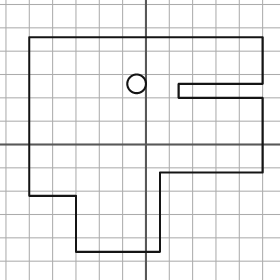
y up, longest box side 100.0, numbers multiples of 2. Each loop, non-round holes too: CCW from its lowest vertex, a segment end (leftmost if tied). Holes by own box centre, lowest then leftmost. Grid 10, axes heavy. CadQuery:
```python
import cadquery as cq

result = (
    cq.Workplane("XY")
    .moveTo(-30.0, -46.0)
    .lineTo(6.0, -46.0)
    .lineTo(6.0, -12.0)
    .lineTo(50.0, -12.0)
    .lineTo(50.0, 20.0)
    .lineTo(14.0, 20.0)
    .lineTo(14.0, 26.0)
    .lineTo(50.0, 26.0)
    .lineTo(50.0, 46.0)
    .lineTo(-50.0, 46.0)
    .lineTo(-50.0, -22.0)
    .lineTo(-30.0, -22.0)
    .close()
    .moveTo(-4.0, 26.0)
    .circle(4.0)
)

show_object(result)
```